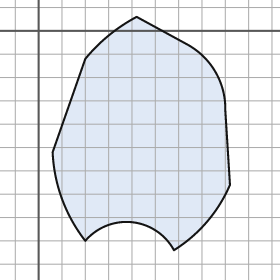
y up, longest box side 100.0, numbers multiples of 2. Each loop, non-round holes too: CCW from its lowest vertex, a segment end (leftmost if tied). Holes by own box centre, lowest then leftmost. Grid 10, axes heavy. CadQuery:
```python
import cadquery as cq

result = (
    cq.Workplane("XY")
    .moveTo(58.0, -94.0)
    .threePointArc((72.0, -82.0), (82.0, -66.0))
    .lineTo(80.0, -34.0)
    .threePointArc((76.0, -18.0), (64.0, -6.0))
    .lineTo(42.0, 6.0)
    .threePointArc((30.0, -2.0), (20.0, -12.0))
    .lineTo(6.0, -52.0)
    .threePointArc((10.0, -72.0), (20.0, -90.0))
    .threePointArc((40.0, -82.0), (58.0, -94.0))
    .close()
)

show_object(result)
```